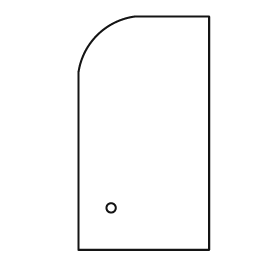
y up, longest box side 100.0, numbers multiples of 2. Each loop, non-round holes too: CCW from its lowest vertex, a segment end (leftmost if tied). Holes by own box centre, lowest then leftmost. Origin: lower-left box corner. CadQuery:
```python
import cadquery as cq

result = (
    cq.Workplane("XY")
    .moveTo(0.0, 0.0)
    .lineTo(56.0, 0.0)
    .lineTo(56.0, 100.0)
    .lineTo(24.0, 100.0)
    .threePointArc((8.0, 92.0), (0.0, 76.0))
    .close()
    .moveTo(14.0, 18.0)
    .circle(2.0)
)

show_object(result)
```